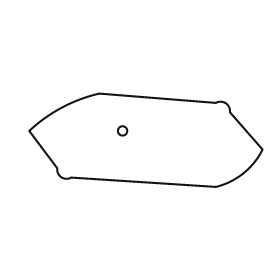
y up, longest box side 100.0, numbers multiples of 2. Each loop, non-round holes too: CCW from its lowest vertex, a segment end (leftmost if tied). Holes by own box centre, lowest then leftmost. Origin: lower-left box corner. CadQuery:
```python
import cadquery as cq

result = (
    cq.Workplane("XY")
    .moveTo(80.0, 0.0)
    .threePointArc((92.0, 6.0), (100.0, 16.0))
    .lineTo(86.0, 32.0)
    .threePointArc((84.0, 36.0), (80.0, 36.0))
    .lineTo(30.0, 40.0)
    .threePointArc((14.0, 34.0), (0.0, 24.0))
    .lineTo(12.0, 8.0)
    .threePointArc((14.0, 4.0), (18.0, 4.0))
    .close()
    .moveTo(40.0, 24.0)
    .circle(2.0)
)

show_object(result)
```